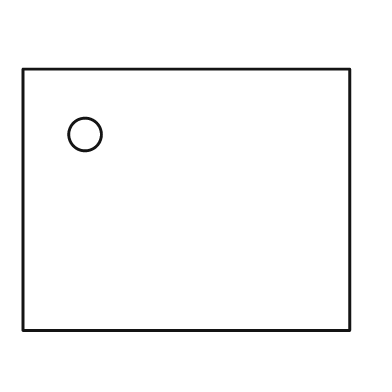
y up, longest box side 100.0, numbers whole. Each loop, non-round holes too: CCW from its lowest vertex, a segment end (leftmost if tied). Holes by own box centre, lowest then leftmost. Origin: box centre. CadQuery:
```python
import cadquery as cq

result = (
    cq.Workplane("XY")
    .moveTo(-50.0, -40.0)
    .lineTo(50.0, -40.0)
    .lineTo(50.0, 40.0)
    .lineTo(-50.0, 40.0)
    .close()
    .moveTo(-31.0, 20.0)
    .circle(5.0)
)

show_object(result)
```